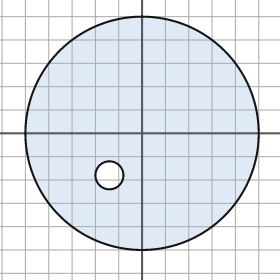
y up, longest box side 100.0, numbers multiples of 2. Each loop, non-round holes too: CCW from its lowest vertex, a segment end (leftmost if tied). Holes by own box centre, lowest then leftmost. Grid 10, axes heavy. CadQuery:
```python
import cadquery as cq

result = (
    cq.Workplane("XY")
    .moveTo(0.0, 0.0)
    .circle(50.0)
    .moveTo(-14.0, -18.0)
    .circle(6.0)
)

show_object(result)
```